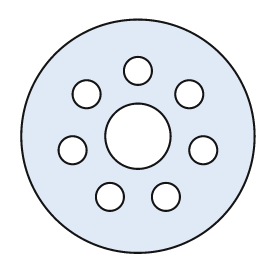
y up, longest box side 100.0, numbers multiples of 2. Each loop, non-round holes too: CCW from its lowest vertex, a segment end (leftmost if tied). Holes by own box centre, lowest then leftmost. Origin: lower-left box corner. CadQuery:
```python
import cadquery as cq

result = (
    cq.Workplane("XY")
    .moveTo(50.0, 50.0)
    .circle(50.0)
    .moveTo(38.0, 24.0)
    .circle(6.0)
    .moveTo(62.0, 24.0)
    .circle(6.0)
    .moveTo(22.0, 44.0)
    .circle(6.0)
    .moveTo(78.0, 44.0)
    .circle(6.0)
    .moveTo(50.0, 50.0)
    .circle(14.0)
    .moveTo(28.0, 68.0)
    .circle(6.0)
    .moveTo(72.0, 68.0)
    .circle(6.0)
    .moveTo(50.0, 78.0)
    .circle(6.0)
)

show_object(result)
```